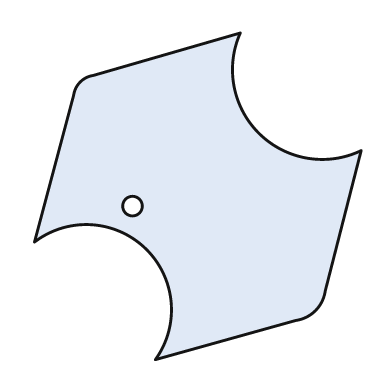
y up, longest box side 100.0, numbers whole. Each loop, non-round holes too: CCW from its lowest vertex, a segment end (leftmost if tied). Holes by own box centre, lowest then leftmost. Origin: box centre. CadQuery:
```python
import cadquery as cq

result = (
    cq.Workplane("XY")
    .moveTo(-13.0, -50.0)
    .lineTo(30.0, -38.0)
    .threePointArc((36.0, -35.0), (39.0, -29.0))
    .lineTo(50.0, 14.0)
    .threePointArc((19.0, 19.0), (13.0, 50.0))
    .lineTo(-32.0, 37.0)
    .threePointArc((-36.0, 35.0), (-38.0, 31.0))
    .lineTo(-50.0, -14.0)
    .threePointArc((-16.0, -16.0), (-13.0, -50.0))
    .close()
    .moveTo(-20.0, -3.0)
    .circle(3.0)
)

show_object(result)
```